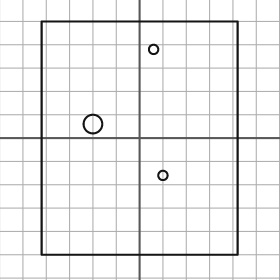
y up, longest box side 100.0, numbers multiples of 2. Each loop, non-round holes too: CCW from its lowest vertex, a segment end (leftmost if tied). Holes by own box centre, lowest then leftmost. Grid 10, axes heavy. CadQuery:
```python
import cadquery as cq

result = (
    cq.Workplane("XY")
    .moveTo(-42.0, -50.0)
    .lineTo(42.0, -50.0)
    .lineTo(42.0, 50.0)
    .lineTo(-42.0, 50.0)
    .close()
    .moveTo(10.0, -16.0)
    .circle(2.0)
    .moveTo(-20.0, 6.0)
    .circle(4.0)
    .moveTo(6.0, 38.0)
    .circle(2.0)
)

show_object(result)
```